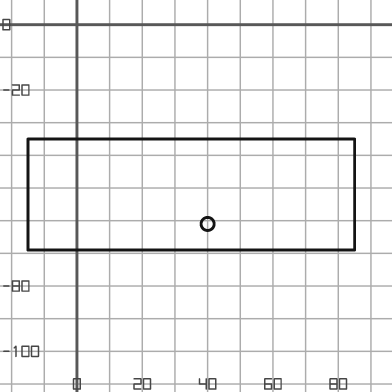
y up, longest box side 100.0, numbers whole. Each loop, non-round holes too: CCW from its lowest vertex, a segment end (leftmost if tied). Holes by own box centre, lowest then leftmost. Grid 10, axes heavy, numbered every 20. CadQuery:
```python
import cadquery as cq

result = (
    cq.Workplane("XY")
    .moveTo(-15.0, -69.0)
    .lineTo(85.0, -69.0)
    .lineTo(85.0, -35.0)
    .lineTo(-15.0, -35.0)
    .close()
    .moveTo(40.0, -61.0)
    .circle(2.0)
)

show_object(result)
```